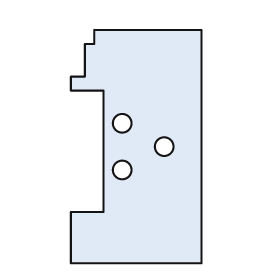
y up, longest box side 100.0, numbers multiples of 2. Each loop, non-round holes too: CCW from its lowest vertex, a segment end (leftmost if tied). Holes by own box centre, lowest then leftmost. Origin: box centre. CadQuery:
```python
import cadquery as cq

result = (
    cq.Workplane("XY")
    .moveTo(-28.0, -50.0)
    .lineTo(28.0, -50.0)
    .lineTo(28.0, 50.0)
    .lineTo(-18.0, 50.0)
    .lineTo(-18.0, 44.0)
    .lineTo(-22.0, 44.0)
    .lineTo(-22.0, 30.0)
    .lineTo(-28.0, 30.0)
    .lineTo(-28.0, 24.0)
    .lineTo(-14.0, 24.0)
    .lineTo(-14.0, -28.0)
    .lineTo(-28.0, -28.0)
    .close()
    .moveTo(-6.0, -10.0)
    .circle(4.0)
    .moveTo(12.0, 0.0)
    .circle(4.0)
    .moveTo(-6.0, 10.0)
    .circle(4.0)
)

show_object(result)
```